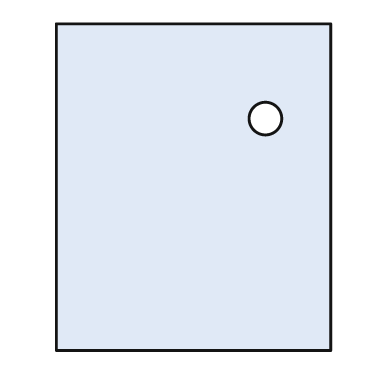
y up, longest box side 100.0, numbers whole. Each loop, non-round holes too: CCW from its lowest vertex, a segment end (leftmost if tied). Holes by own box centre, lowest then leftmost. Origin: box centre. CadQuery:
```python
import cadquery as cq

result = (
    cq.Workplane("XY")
    .moveTo(-42.0, -50.0)
    .lineTo(42.0, -50.0)
    .lineTo(42.0, 50.0)
    .lineTo(-42.0, 50.0)
    .close()
    .moveTo(22.0, 21.0)
    .circle(5.0)
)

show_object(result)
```